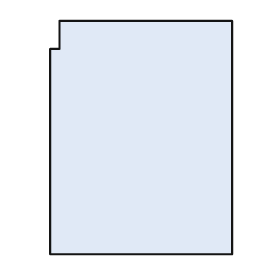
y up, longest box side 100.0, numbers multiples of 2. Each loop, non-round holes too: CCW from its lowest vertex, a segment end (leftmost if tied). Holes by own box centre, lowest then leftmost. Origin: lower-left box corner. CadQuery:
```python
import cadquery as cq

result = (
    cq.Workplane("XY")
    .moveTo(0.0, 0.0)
    .lineTo(78.0, 0.0)
    .lineTo(78.0, 100.0)
    .lineTo(4.0, 100.0)
    .lineTo(4.0, 88.0)
    .lineTo(0.0, 88.0)
    .close()
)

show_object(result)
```